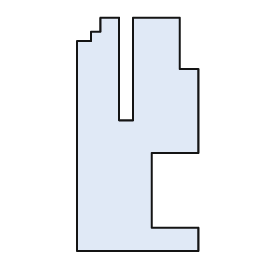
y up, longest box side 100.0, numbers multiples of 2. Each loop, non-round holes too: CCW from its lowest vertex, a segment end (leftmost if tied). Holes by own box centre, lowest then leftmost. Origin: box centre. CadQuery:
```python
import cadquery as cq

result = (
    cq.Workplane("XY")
    .moveTo(-26.0, -50.0)
    .lineTo(26.0, -50.0)
    .lineTo(26.0, -40.0)
    .lineTo(6.0, -40.0)
    .lineTo(6.0, -8.0)
    .lineTo(26.0, -8.0)
    .lineTo(26.0, 28.0)
    .lineTo(18.0, 28.0)
    .lineTo(18.0, 50.0)
    .lineTo(-2.0, 50.0)
    .lineTo(-2.0, 6.0)
    .lineTo(-8.0, 6.0)
    .lineTo(-8.0, 50.0)
    .lineTo(-16.0, 50.0)
    .lineTo(-16.0, 44.0)
    .lineTo(-20.0, 44.0)
    .lineTo(-20.0, 40.0)
    .lineTo(-26.0, 40.0)
    .close()
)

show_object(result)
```